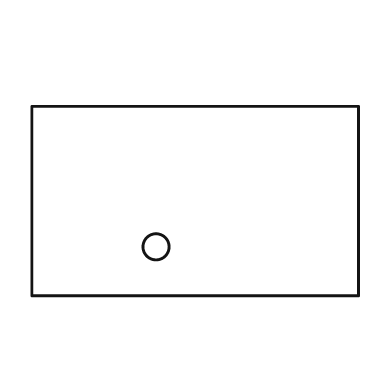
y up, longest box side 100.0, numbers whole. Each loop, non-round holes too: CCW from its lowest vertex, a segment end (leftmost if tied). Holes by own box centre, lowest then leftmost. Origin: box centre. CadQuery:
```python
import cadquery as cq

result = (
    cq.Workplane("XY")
    .moveTo(-50.0, -29.0)
    .lineTo(50.0, -29.0)
    .lineTo(50.0, 29.0)
    .lineTo(-50.0, 29.0)
    .close()
    .moveTo(-12.0, -14.0)
    .circle(4.0)
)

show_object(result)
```